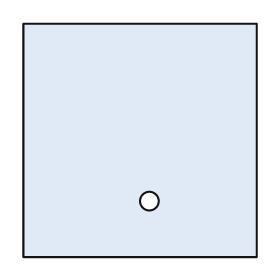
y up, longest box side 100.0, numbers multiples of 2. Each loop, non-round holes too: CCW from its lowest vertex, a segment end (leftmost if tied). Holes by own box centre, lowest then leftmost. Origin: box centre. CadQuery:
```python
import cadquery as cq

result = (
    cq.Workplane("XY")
    .moveTo(-50.0, -50.0)
    .lineTo(50.0, -50.0)
    .lineTo(50.0, 50.0)
    .lineTo(-50.0, 50.0)
    .close()
    .moveTo(4.0, -26.0)
    .circle(4.0)
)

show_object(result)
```